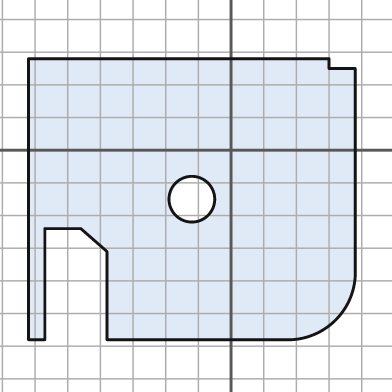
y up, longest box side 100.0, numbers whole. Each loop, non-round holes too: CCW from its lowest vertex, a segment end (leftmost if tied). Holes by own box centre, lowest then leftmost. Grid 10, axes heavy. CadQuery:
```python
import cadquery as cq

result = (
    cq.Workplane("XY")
    .moveTo(-62.0, -58.0)
    .lineTo(-57.0, -58.0)
    .lineTo(-57.0, -24.0)
    .lineTo(-46.0, -24.0)
    .lineTo(-38.0, -31.0)
    .lineTo(-38.0, -58.0)
    .lineTo(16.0, -58.0)
    .threePointArc((32.0, -52.0), (38.0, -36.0))
    .lineTo(38.0, 25.0)
    .lineTo(30.0, 25.0)
    .lineTo(30.0, 28.0)
    .lineTo(-62.0, 28.0)
    .close()
    .moveTo(-12.0, -15.0)
    .circle(7.0)
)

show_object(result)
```